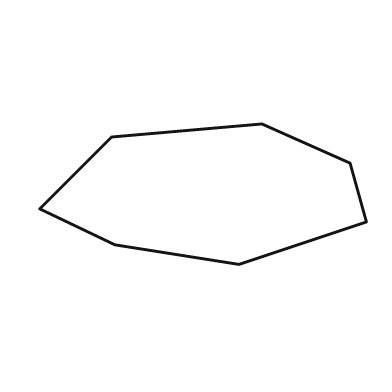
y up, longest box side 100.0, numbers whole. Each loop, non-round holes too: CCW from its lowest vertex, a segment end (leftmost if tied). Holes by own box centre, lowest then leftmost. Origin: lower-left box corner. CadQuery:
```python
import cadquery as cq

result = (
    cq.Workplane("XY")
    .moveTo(61.0, 0.0)
    .lineTo(100.0, 13.0)
    .lineTo(95.0, 31.0)
    .lineTo(68.0, 43.0)
    .lineTo(22.0, 39.0)
    .lineTo(0.0, 17.0)
    .lineTo(23.0, 6.0)
    .close()
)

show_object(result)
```